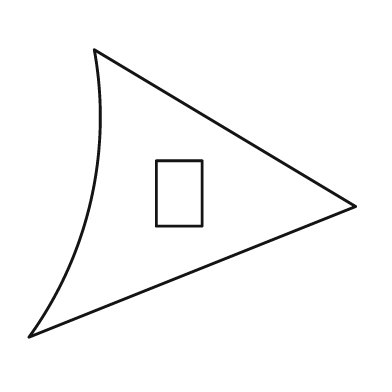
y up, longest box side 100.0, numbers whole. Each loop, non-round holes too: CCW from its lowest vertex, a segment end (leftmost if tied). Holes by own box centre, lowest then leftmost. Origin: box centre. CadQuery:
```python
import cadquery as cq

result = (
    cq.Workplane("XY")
    .moveTo(-50.0, -44.0)
    .lineTo(50.0, -4.0)
    .lineTo(-30.0, 44.0)
    .threePointArc((-31.0, -2.0), (-50.0, -44.0))
    .close()
    .moveTo(-11.0, -10.0)
    .lineTo(3.0, -10.0)
    .lineTo(3.0, 10.0)
    .lineTo(-11.0, 10.0)
    .close()
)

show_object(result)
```